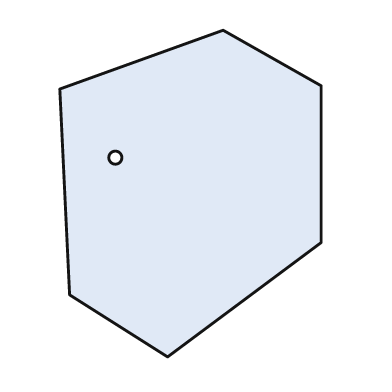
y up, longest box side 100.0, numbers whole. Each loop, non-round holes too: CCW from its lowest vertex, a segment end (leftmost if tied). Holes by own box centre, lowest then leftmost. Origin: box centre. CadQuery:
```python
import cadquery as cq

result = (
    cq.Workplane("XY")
    .moveTo(-7.0, -50.0)
    .lineTo(40.0, -15.0)
    .lineTo(40.0, 33.0)
    .lineTo(10.0, 50.0)
    .lineTo(-40.0, 32.0)
    .lineTo(-37.0, -31.0)
    .close()
    .moveTo(-23.0, 11.0)
    .circle(2.0)
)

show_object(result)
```